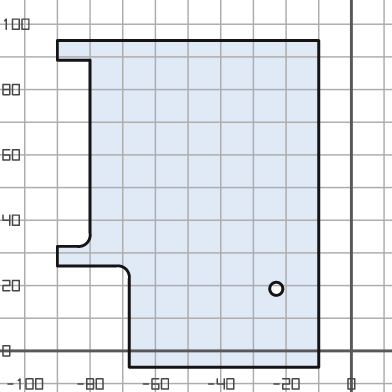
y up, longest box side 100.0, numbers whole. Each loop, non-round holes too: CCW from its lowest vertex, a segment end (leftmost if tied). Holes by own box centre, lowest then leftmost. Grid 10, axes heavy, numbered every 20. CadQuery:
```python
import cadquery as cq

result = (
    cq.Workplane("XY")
    .moveTo(-68.0, -5.0)
    .lineTo(-10.0, -5.0)
    .lineTo(-10.0, 95.0)
    .lineTo(-90.0, 95.0)
    .lineTo(-90.0, 89.0)
    .lineTo(-80.0, 89.0)
    .lineTo(-80.0, 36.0)
    .threePointArc((-81.0, 33.0), (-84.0, 32.0))
    .lineTo(-90.0, 32.0)
    .lineTo(-90.0, 26.0)
    .lineTo(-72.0, 26.0)
    .threePointArc((-69.0, 25.0), (-68.0, 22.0))
    .close()
    .moveTo(-23.0, 19.0)
    .circle(2.0)
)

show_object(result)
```